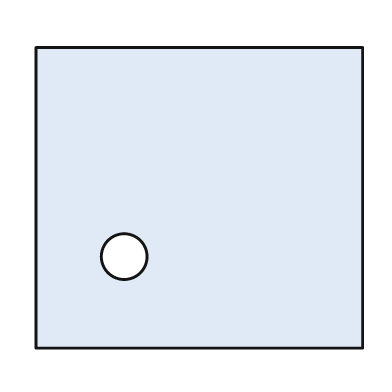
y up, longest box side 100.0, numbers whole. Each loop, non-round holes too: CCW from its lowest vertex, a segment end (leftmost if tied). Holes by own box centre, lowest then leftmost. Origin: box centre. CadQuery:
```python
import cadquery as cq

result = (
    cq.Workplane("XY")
    .moveTo(-50.0, -46.0)
    .lineTo(50.0, -46.0)
    .lineTo(50.0, 46.0)
    .lineTo(-50.0, 46.0)
    .close()
    .moveTo(-23.0, -18.0)
    .circle(7.0)
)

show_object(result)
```